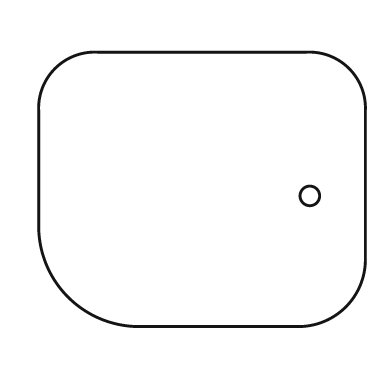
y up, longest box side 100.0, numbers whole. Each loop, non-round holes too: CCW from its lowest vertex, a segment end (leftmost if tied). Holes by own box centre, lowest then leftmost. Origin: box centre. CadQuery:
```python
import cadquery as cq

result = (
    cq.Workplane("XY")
    .moveTo(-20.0, -42.0)
    .lineTo(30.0, -42.0)
    .threePointArc((44.0, -36.0), (50.0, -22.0))
    .lineTo(50.0, 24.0)
    .threePointArc((45.0, 37.0), (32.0, 42.0))
    .lineTo(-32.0, 42.0)
    .threePointArc((-45.0, 37.0), (-50.0, 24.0))
    .lineTo(-50.0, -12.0)
    .threePointArc((-41.0, -33.0), (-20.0, -42.0))
    .close()
    .moveTo(33.0, -2.0)
    .circle(3.0)
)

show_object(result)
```